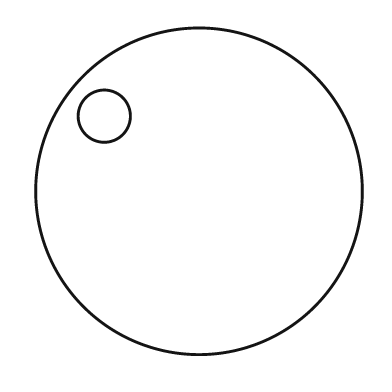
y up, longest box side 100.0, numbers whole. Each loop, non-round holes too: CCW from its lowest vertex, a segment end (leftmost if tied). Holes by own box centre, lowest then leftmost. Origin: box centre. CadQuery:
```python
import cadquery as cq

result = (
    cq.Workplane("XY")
    .moveTo(0.0, 0.0)
    .circle(50.0)
    .moveTo(-29.0, 23.0)
    .circle(8.0)
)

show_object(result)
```